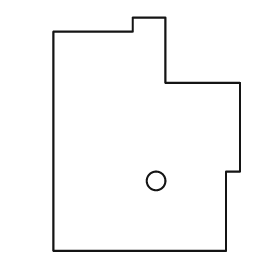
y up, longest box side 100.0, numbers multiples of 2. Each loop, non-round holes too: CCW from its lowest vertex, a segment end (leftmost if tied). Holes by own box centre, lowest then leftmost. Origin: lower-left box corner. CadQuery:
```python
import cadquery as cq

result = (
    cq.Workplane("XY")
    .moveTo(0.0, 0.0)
    .lineTo(74.0, 0.0)
    .lineTo(74.0, 34.0)
    .lineTo(80.0, 34.0)
    .lineTo(80.0, 72.0)
    .lineTo(48.0, 72.0)
    .lineTo(48.0, 100.0)
    .lineTo(34.0, 100.0)
    .lineTo(34.0, 94.0)
    .lineTo(0.0, 94.0)
    .close()
    .moveTo(44.0, 30.0)
    .circle(4.0)
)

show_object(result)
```